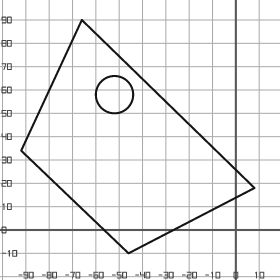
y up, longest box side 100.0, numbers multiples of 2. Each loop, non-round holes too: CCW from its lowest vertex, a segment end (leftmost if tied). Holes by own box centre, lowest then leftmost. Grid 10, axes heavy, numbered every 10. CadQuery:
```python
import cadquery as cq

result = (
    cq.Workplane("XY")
    .moveTo(-46.0, -10.0)
    .lineTo(8.0, 18.0)
    .lineTo(-66.0, 90.0)
    .lineTo(-92.0, 34.0)
    .close()
    .moveTo(-52.0, 58.0)
    .circle(8.0)
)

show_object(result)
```